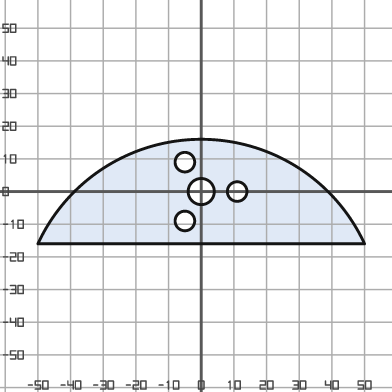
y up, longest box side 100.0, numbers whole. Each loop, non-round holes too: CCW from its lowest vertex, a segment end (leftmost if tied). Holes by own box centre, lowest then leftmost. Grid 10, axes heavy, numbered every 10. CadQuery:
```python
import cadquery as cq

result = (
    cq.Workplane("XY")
    .moveTo(-50.0, -16.0)
    .lineTo(50.0, -16.0)
    .threePointArc((0.0, 16.0), (-50.0, -16.0))
    .close()
    .moveTo(-5.0, -9.0)
    .circle(3.0)
    .moveTo(0.0, 0.0)
    .circle(4.0)
    .moveTo(11.0, 0.0)
    .circle(3.0)
    .moveTo(-5.0, 9.0)
    .circle(3.0)
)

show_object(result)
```